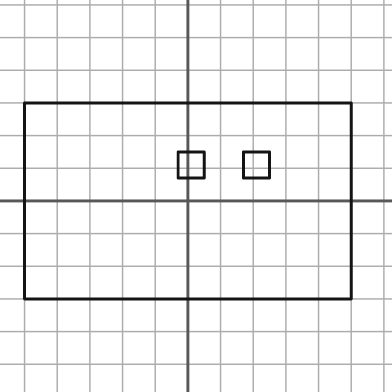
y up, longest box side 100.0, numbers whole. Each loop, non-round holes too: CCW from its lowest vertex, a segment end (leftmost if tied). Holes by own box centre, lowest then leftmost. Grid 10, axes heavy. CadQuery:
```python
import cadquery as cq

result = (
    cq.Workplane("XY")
    .moveTo(-50.0, -30.0)
    .lineTo(50.0, -30.0)
    .lineTo(50.0, 30.0)
    .lineTo(-50.0, 30.0)
    .close()
    .moveTo(-3.0, 7.0)
    .lineTo(5.0, 7.0)
    .lineTo(5.0, 15.0)
    .lineTo(-3.0, 15.0)
    .close()
    .moveTo(17.0, 7.0)
    .lineTo(25.0, 7.0)
    .lineTo(25.0, 15.0)
    .lineTo(17.0, 15.0)
    .close()
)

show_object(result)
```